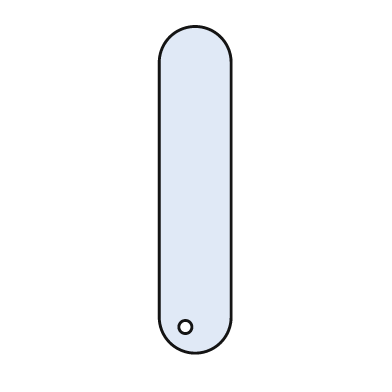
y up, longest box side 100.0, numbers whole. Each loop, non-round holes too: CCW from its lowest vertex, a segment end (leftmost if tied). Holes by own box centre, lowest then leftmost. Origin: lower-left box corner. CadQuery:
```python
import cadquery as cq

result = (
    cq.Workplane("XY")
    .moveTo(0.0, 11.0)
    .threePointArc((11.0, 0.0), (22.0, 11.0))
    .lineTo(22.0, 89.0)
    .threePointArc((11.0, 100.0), (0.0, 89.0))
    .close()
    .moveTo(8.0, 8.0)
    .circle(2.0)
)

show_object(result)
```